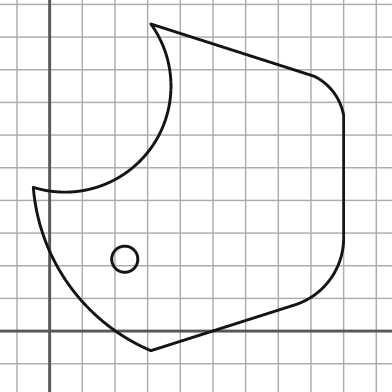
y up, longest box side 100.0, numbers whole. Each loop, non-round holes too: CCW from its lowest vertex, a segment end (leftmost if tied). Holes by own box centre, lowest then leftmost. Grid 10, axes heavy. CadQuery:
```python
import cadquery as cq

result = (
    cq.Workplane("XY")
    .moveTo(31.0, -6.0)
    .lineTo(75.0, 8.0)
    .threePointArc((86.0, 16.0), (90.0, 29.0))
    .lineTo(90.0, 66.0)
    .threePointArc((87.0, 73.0), (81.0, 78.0))
    .lineTo(31.0, 94.0)
    .threePointArc((31.0, 56.0), (-5.0, 44.0))
    .threePointArc((6.0, 14.0), (31.0, -6.0))
    .close()
    .moveTo(23.0, 22.0)
    .circle(4.0)
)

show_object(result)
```